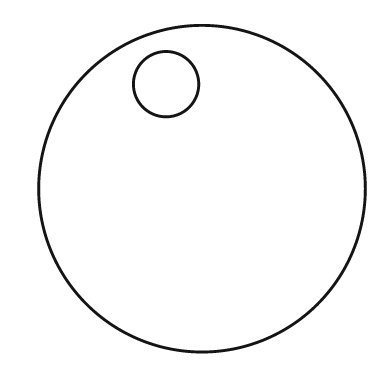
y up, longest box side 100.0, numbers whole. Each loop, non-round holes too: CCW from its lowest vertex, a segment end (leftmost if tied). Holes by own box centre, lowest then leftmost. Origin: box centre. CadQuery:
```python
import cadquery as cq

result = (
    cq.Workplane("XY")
    .moveTo(0.0, 0.0)
    .circle(50.0)
    .moveTo(-11.0, 32.0)
    .circle(10.0)
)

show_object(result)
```